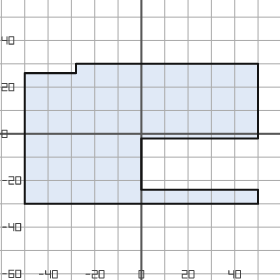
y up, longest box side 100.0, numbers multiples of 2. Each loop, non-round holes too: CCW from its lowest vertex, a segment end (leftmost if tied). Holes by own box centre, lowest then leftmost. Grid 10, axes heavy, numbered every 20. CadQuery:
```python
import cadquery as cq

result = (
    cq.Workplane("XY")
    .moveTo(-50.0, -30.0)
    .lineTo(50.0, -30.0)
    .lineTo(50.0, -24.0)
    .lineTo(0.0, -24.0)
    .lineTo(0.0, -2.0)
    .lineTo(50.0, -2.0)
    .lineTo(50.0, 30.0)
    .lineTo(-28.0, 30.0)
    .lineTo(-28.0, 26.0)
    .lineTo(-50.0, 26.0)
    .close()
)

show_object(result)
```